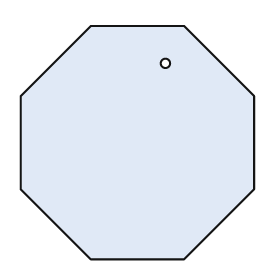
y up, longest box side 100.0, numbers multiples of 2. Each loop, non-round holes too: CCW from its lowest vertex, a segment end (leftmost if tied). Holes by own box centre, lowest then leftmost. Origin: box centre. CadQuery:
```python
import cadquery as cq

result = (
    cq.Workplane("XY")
    .moveTo(-20.0, -50.0)
    .lineTo(20.0, -50.0)
    .lineTo(50.0, -20.0)
    .lineTo(50.0, 20.0)
    .lineTo(20.0, 50.0)
    .lineTo(-20.0, 50.0)
    .lineTo(-50.0, 20.0)
    .lineTo(-50.0, -20.0)
    .close()
    .moveTo(12.0, 34.0)
    .circle(2.0)
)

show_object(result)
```